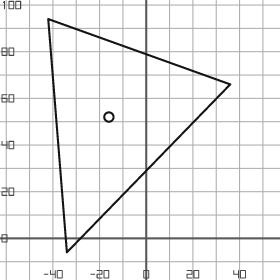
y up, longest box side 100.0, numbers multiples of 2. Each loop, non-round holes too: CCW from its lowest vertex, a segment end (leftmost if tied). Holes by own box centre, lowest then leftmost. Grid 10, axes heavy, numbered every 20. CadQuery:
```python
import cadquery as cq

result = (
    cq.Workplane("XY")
    .moveTo(-34.0, -6.0)
    .lineTo(36.0, 66.0)
    .lineTo(-42.0, 94.0)
    .close()
    .moveTo(-16.0, 52.0)
    .circle(2.0)
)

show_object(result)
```